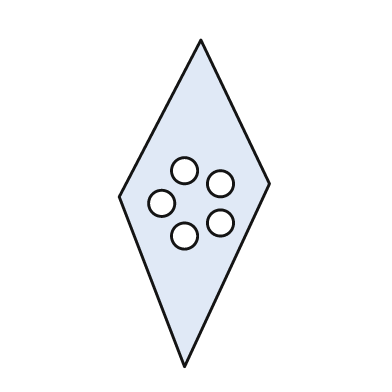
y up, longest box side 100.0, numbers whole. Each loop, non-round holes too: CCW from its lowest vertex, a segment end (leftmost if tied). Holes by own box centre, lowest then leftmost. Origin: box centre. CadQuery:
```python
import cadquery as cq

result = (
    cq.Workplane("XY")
    .moveTo(-3.0, -50.0)
    .lineTo(23.0, 6.0)
    .lineTo(2.0, 50.0)
    .lineTo(-23.0, 2.0)
    .close()
    .moveTo(-3.0, -10.0)
    .circle(4.0)
    .moveTo(8.0, -6.0)
    .circle(4.0)
    .moveTo(-10.0, 0.0)
    .circle(4.0)
    .moveTo(8.0, 6.0)
    .circle(4.0)
    .moveTo(-3.0, 10.0)
    .circle(4.0)
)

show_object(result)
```